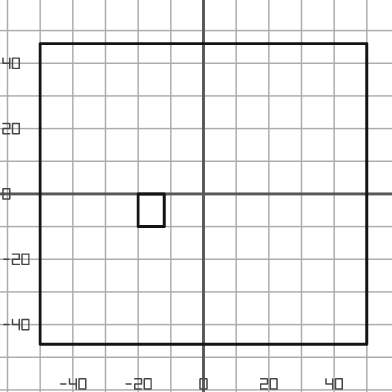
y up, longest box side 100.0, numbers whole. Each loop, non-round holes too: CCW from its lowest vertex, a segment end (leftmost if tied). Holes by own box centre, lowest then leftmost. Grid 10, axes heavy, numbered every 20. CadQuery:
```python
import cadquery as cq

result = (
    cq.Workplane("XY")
    .moveTo(-50.0, -46.0)
    .lineTo(50.0, -46.0)
    .lineTo(50.0, 46.0)
    .lineTo(-50.0, 46.0)
    .close()
    .moveTo(-20.0, -10.0)
    .lineTo(-12.0, -10.0)
    .lineTo(-12.0, 0.0)
    .lineTo(-20.0, 0.0)
    .close()
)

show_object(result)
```